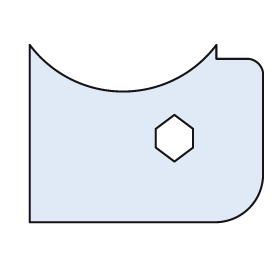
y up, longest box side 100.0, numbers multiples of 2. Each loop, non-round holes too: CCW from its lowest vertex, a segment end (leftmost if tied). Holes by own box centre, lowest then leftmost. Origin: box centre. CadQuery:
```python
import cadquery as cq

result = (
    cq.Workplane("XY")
    .moveTo(-50.0, -38.0)
    .lineTo(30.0, -38.0)
    .threePointArc((44.0, -32.0), (50.0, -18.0))
    .lineTo(50.0, 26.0)
    .threePointArc((48.0, 30.0), (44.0, 32.0))
    .lineTo(30.0, 32.0)
    .lineTo(30.0, 38.0)
    .threePointArc((-10.0, 18.0), (-50.0, 38.0))
    .close()
    .moveTo(12.0, -12.0)
    .lineTo(20.0, -6.0)
    .lineTo(20.0, 2.0)
    .lineTo(12.0, 8.0)
    .lineTo(4.0, 2.0)
    .lineTo(4.0, -6.0)
    .close()
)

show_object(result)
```